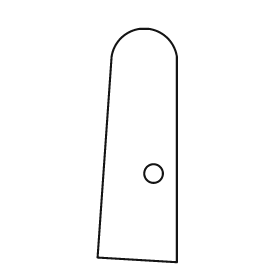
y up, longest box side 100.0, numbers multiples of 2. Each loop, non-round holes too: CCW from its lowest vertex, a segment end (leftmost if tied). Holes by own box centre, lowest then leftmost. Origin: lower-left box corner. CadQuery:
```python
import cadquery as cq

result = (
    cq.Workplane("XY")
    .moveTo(34.0, 0.0)
    .lineTo(34.0, 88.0)
    .threePointArc((30.0, 96.0), (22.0, 100.0))
    .lineTo(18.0, 100.0)
    .threePointArc((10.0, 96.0), (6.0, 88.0))
    .lineTo(0.0, 2.0)
    .close()
    .moveTo(24.0, 38.0)
    .circle(4.0)
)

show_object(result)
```